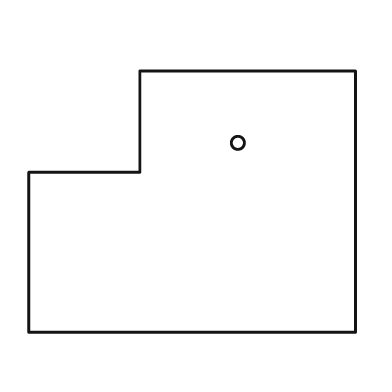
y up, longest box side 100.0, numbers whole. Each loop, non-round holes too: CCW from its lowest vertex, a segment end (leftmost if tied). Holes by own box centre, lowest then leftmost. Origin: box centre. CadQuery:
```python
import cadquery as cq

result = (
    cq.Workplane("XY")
    .moveTo(-50.0, -40.0)
    .lineTo(50.0, -40.0)
    .lineTo(50.0, 40.0)
    .lineTo(-16.0, 40.0)
    .lineTo(-16.0, 9.0)
    .lineTo(-50.0, 9.0)
    .close()
    .moveTo(14.0, 18.0)
    .circle(2.0)
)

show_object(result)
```